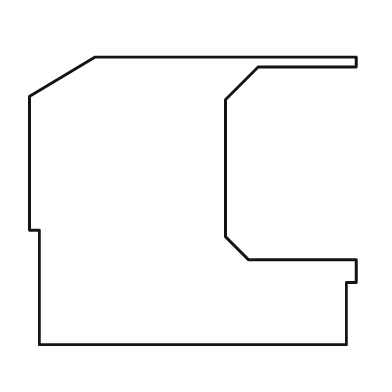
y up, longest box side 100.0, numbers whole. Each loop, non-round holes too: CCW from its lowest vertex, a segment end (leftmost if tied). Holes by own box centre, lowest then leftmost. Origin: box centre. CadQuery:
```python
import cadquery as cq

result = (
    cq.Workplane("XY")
    .moveTo(-47.0, -44.0)
    .lineTo(47.0, -44.0)
    .lineTo(47.0, -25.0)
    .lineTo(50.0, -25.0)
    .lineTo(50.0, -18.0)
    .lineTo(17.0, -18.0)
    .lineTo(10.0, -11.0)
    .lineTo(10.0, 31.0)
    .lineTo(20.0, 41.0)
    .lineTo(50.0, 41.0)
    .lineTo(50.0, 44.0)
    .lineTo(-30.0, 44.0)
    .lineTo(-50.0, 32.0)
    .lineTo(-50.0, -9.0)
    .lineTo(-47.0, -9.0)
    .close()
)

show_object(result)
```